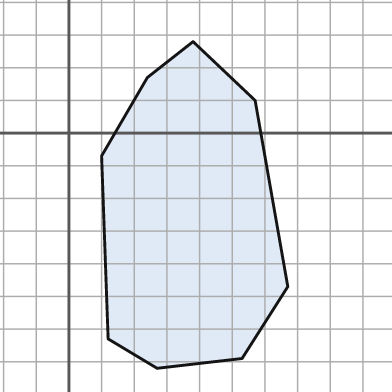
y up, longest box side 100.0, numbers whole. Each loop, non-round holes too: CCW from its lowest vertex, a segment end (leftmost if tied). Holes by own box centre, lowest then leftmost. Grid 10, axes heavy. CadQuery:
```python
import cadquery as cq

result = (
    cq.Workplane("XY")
    .moveTo(27.0, -72.0)
    .lineTo(53.0, -69.0)
    .lineTo(67.0, -47.0)
    .lineTo(57.0, 10.0)
    .lineTo(38.0, 28.0)
    .lineTo(24.0, 17.0)
    .lineTo(10.0, -7.0)
    .lineTo(12.0, -63.0)
    .close()
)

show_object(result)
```